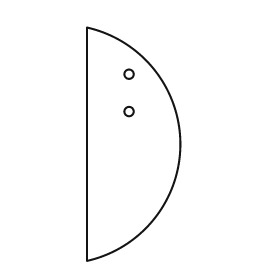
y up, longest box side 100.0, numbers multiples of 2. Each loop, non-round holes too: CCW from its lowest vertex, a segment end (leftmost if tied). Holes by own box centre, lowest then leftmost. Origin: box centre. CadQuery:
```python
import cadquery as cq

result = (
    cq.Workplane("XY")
    .moveTo(-20.0, -50.0)
    .threePointArc((20.0, 0.0), (-20.0, 50.0))
    .close()
    .moveTo(-2.0, 14.0)
    .circle(2.0)
    .moveTo(-2.0, 30.0)
    .circle(2.0)
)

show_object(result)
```